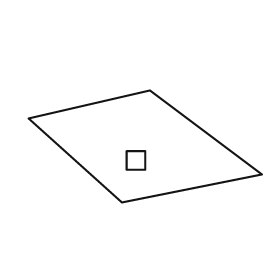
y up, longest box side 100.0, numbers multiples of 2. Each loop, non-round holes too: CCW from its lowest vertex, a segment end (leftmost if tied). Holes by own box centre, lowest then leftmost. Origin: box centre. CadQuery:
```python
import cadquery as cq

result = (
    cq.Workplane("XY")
    .moveTo(-10.0, -24.0)
    .lineTo(50.0, -12.0)
    .lineTo(2.0, 24.0)
    .lineTo(-50.0, 12.0)
    .close()
    .moveTo(-8.0, -10.0)
    .lineTo(0.0, -10.0)
    .lineTo(0.0, -2.0)
    .lineTo(-8.0, -2.0)
    .close()
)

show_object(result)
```